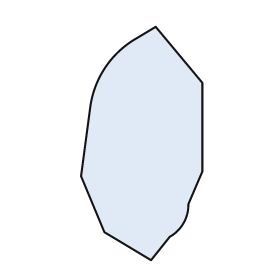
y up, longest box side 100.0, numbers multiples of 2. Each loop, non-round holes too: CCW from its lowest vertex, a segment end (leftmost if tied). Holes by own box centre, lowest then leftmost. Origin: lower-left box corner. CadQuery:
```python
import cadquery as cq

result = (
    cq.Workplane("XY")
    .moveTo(30.0, 0.0)
    .lineTo(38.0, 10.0)
    .threePointArc((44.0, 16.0), (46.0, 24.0))
    .lineTo(52.0, 38.0)
    .lineTo(52.0, 76.0)
    .lineTo(32.0, 100.0)
    .lineTo(22.0, 94.0)
    .threePointArc((10.0, 82.0), (4.0, 66.0))
    .lineTo(0.0, 36.0)
    .lineTo(10.0, 12.0)
    .close()
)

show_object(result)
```